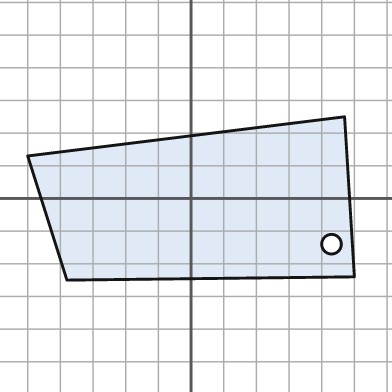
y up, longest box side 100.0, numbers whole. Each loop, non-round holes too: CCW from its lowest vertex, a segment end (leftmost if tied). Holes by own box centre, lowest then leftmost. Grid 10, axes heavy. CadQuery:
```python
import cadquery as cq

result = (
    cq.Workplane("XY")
    .moveTo(-38.0, -25.0)
    .lineTo(50.0, -24.0)
    .lineTo(47.0, 25.0)
    .lineTo(-50.0, 13.0)
    .close()
    .moveTo(43.0, -14.0)
    .circle(3.0)
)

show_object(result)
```